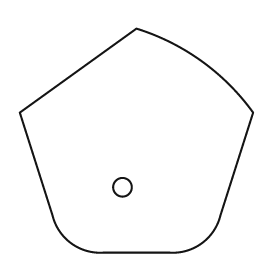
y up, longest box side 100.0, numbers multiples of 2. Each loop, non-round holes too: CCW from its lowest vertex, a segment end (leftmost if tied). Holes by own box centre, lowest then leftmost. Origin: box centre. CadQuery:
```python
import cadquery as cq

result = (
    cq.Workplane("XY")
    .moveTo(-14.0, -48.0)
    .lineTo(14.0, -48.0)
    .threePointArc((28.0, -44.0), (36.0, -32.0))
    .lineTo(50.0, 12.0)
    .threePointArc((28.0, 34.0), (0.0, 48.0))
    .lineTo(-50.0, 12.0)
    .lineTo(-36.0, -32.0)
    .threePointArc((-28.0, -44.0), (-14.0, -48.0))
    .close()
    .moveTo(-6.0, -20.0)
    .circle(4.0)
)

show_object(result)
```